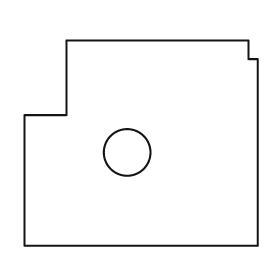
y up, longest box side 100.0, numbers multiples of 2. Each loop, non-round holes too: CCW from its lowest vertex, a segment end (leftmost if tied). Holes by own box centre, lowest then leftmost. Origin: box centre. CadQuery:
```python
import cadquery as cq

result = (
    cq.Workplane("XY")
    .moveTo(-50.0, -44.0)
    .lineTo(50.0, -44.0)
    .lineTo(50.0, 36.0)
    .lineTo(46.0, 36.0)
    .lineTo(46.0, 44.0)
    .lineTo(-32.0, 44.0)
    .lineTo(-32.0, 12.0)
    .lineTo(-50.0, 12.0)
    .close()
    .moveTo(-6.0, -4.0)
    .circle(10.0)
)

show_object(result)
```